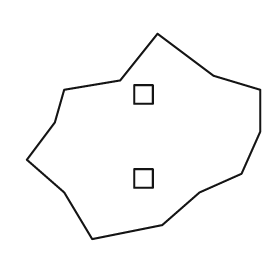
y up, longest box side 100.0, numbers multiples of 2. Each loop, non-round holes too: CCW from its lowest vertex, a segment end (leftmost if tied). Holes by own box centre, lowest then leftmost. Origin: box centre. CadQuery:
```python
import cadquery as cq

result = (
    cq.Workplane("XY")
    .moveTo(-22.0, -44.0)
    .lineTo(8.0, -38.0)
    .lineTo(24.0, -24.0)
    .lineTo(42.0, -16.0)
    .lineTo(50.0, 2.0)
    .lineTo(50.0, 20.0)
    .lineTo(30.0, 26.0)
    .lineTo(6.0, 44.0)
    .lineTo(-10.0, 24.0)
    .lineTo(-34.0, 20.0)
    .lineTo(-38.0, 6.0)
    .lineTo(-50.0, -10.0)
    .lineTo(-34.0, -24.0)
    .close()
    .moveTo(-4.0, -22.0)
    .lineTo(4.0, -22.0)
    .lineTo(4.0, -14.0)
    .lineTo(-4.0, -14.0)
    .close()
    .moveTo(-4.0, 14.0)
    .lineTo(4.0, 14.0)
    .lineTo(4.0, 22.0)
    .lineTo(-4.0, 22.0)
    .close()
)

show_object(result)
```